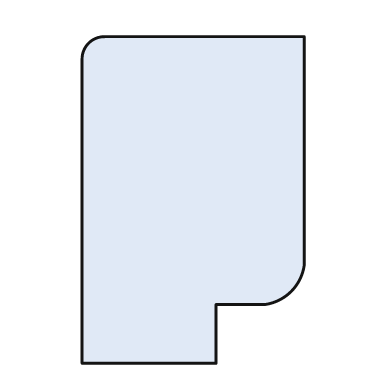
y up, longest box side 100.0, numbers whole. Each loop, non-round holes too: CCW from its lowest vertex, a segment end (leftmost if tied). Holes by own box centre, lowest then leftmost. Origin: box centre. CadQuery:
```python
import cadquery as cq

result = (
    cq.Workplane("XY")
    .moveTo(-34.0, -50.0)
    .lineTo(7.0, -50.0)
    .lineTo(7.0, -32.0)
    .lineTo(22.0, -32.0)
    .threePointArc((30.0, -28.0), (34.0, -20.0))
    .lineTo(34.0, 50.0)
    .lineTo(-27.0, 50.0)
    .threePointArc((-32.0, 48.0), (-34.0, 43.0))
    .close()
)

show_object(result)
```